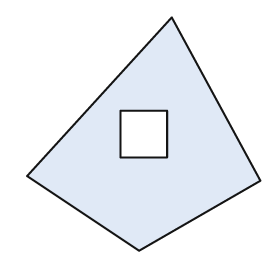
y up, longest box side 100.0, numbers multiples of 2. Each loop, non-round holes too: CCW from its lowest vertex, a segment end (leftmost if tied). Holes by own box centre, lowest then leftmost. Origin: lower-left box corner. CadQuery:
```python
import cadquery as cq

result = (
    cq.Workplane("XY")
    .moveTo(48.0, 0.0)
    .lineTo(100.0, 30.0)
    .lineTo(62.0, 100.0)
    .lineTo(0.0, 32.0)
    .close()
    .moveTo(40.0, 40.0)
    .lineTo(60.0, 40.0)
    .lineTo(60.0, 60.0)
    .lineTo(40.0, 60.0)
    .close()
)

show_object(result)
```